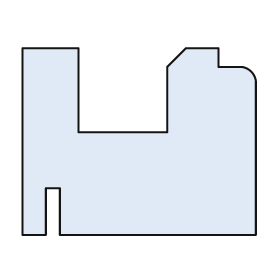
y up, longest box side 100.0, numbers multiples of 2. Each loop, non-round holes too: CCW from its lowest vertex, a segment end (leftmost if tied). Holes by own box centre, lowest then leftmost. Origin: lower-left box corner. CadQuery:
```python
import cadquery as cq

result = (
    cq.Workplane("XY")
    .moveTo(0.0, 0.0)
    .lineTo(10.0, 0.0)
    .lineTo(10.0, 20.0)
    .lineTo(16.0, 20.0)
    .lineTo(16.0, 0.0)
    .lineTo(100.0, 0.0)
    .lineTo(100.0, 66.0)
    .threePointArc((98.0, 70.0), (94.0, 72.0))
    .lineTo(84.0, 72.0)
    .lineTo(84.0, 80.0)
    .lineTo(70.0, 80.0)
    .lineTo(62.0, 72.0)
    .lineTo(62.0, 44.0)
    .lineTo(24.0, 44.0)
    .lineTo(24.0, 80.0)
    .lineTo(0.0, 80.0)
    .close()
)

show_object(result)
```